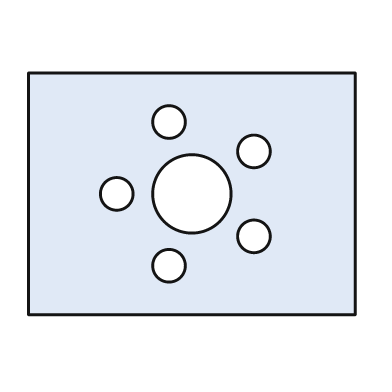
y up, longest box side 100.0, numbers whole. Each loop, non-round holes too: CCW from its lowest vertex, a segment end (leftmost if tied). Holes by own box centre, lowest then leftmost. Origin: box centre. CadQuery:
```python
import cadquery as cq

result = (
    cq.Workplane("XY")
    .moveTo(-50.0, -37.0)
    .lineTo(50.0, -37.0)
    .lineTo(50.0, 37.0)
    .lineTo(-50.0, 37.0)
    .close()
    .moveTo(-7.0, -22.0)
    .circle(5.0)
    .moveTo(19.0, -13.0)
    .circle(5.0)
    .moveTo(-23.0, 0.0)
    .circle(5.0)
    .moveTo(0.0, 0.0)
    .circle(12.0)
    .moveTo(19.0, 13.0)
    .circle(5.0)
    .moveTo(-7.0, 22.0)
    .circle(5.0)
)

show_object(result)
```